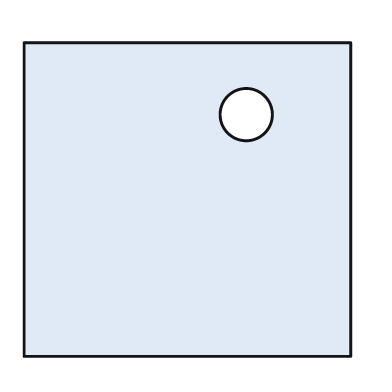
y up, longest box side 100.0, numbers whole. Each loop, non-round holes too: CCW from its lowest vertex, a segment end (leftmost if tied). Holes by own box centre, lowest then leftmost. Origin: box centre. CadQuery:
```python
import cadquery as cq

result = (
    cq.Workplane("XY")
    .moveTo(-50.0, -48.0)
    .lineTo(50.0, -48.0)
    .lineTo(50.0, 48.0)
    .lineTo(-50.0, 48.0)
    .close()
    .moveTo(18.0, 26.0)
    .circle(8.0)
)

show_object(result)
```